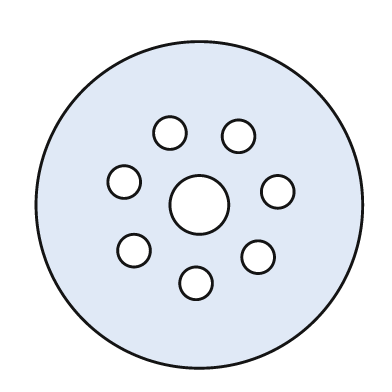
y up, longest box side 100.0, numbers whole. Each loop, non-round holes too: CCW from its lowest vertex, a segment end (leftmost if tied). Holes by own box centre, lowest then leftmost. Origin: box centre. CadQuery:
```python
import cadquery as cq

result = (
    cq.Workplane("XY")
    .moveTo(0.0, 0.0)
    .circle(50.0)
    .moveTo(-1.0, -24.0)
    .circle(5.0)
    .moveTo(18.0, -16.0)
    .circle(5.0)
    .moveTo(-20.0, -14.0)
    .circle(5.0)
    .moveTo(0.0, 0.0)
    .circle(9.0)
    .moveTo(24.0, 4.0)
    .circle(5.0)
    .moveTo(-23.0, 7.0)
    .circle(5.0)
    .moveTo(12.0, 21.0)
    .circle(5.0)
    .moveTo(-9.0, 22.0)
    .circle(5.0)
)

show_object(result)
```